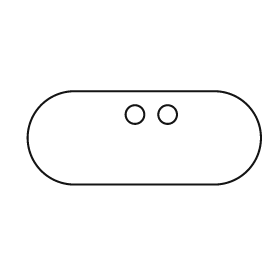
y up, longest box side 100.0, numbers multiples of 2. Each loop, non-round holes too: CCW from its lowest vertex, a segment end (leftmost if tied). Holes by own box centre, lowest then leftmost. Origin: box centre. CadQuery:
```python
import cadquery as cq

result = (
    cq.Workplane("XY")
    .moveTo(-30.0, -20.0)
    .lineTo(30.0, -20.0)
    .threePointArc((50.0, 0.0), (30.0, 20.0))
    .lineTo(-30.0, 20.0)
    .threePointArc((-50.0, 0.0), (-30.0, -20.0))
    .close()
    .moveTo(-4.0, 10.0)
    .circle(4.0)
    .moveTo(10.0, 10.0)
    .circle(4.0)
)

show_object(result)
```